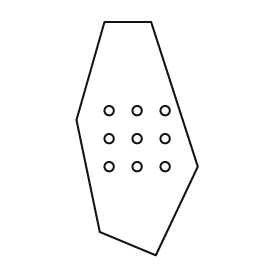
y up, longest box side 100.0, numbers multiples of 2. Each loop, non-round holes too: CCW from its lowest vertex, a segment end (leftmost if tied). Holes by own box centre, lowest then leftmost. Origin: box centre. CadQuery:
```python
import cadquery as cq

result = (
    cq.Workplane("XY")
    .moveTo(8.0, -50.0)
    .lineTo(26.0, -12.0)
    .lineTo(6.0, 50.0)
    .lineTo(-14.0, 50.0)
    .lineTo(-26.0, 8.0)
    .lineTo(-16.0, -40.0)
    .close()
    .moveTo(-12.0, -12.0)
    .circle(2.0)
    .moveTo(0.0, -12.0)
    .circle(2.0)
    .moveTo(12.0, -12.0)
    .circle(2.0)
    .moveTo(-12.0, 0.0)
    .circle(2.0)
    .moveTo(0.0, 0.0)
    .circle(2.0)
    .moveTo(12.0, 0.0)
    .circle(2.0)
    .moveTo(-12.0, 12.0)
    .circle(2.0)
    .moveTo(0.0, 12.0)
    .circle(2.0)
    .moveTo(12.0, 12.0)
    .circle(2.0)
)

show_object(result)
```